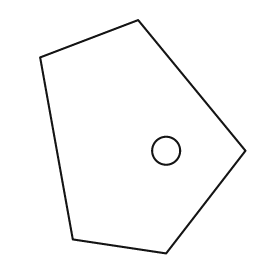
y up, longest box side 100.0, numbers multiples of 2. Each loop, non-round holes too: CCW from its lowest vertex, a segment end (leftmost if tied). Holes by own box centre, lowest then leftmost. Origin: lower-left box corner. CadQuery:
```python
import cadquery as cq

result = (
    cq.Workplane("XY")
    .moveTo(54.0, 0.0)
    .lineTo(88.0, 44.0)
    .lineTo(42.0, 100.0)
    .lineTo(0.0, 84.0)
    .lineTo(14.0, 6.0)
    .close()
    .moveTo(54.0, 44.0)
    .circle(6.0)
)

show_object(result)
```